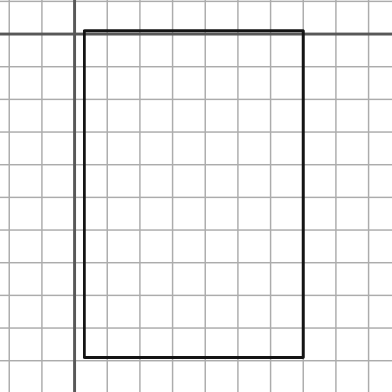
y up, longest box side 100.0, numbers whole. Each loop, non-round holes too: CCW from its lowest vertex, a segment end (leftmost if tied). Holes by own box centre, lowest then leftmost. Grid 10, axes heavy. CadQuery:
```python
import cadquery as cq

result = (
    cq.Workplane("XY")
    .moveTo(3.0, -99.0)
    .lineTo(70.0, -99.0)
    .lineTo(70.0, 1.0)
    .lineTo(3.0, 1.0)
    .close()
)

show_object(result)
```